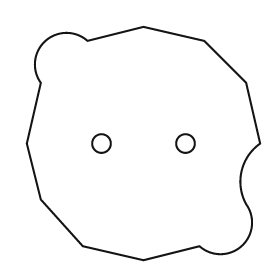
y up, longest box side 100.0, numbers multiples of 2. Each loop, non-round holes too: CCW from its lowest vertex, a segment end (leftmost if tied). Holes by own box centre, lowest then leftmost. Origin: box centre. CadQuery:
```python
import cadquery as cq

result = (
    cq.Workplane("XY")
    .moveTo(0.0, -50.0)
    .lineTo(24.0, -44.0)
    .threePointArc((42.0, -44.0), (44.0, -26.0))
    .threePointArc((42.0, -12.0), (50.0, 0.0))
    .lineTo(44.0, 26.0)
    .lineTo(26.0, 44.0)
    .lineTo(0.0, 50.0)
    .lineTo(-24.0, 44.0)
    .threePointArc((-42.0, 44.0), (-44.0, 26.0))
    .lineTo(-50.0, 0.0)
    .lineTo(-44.0, -24.0)
    .lineTo(-26.0, -44.0)
    .close()
    .moveTo(-18.0, 0.0)
    .circle(4.0)
    .moveTo(18.0, 0.0)
    .circle(4.0)
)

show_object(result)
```